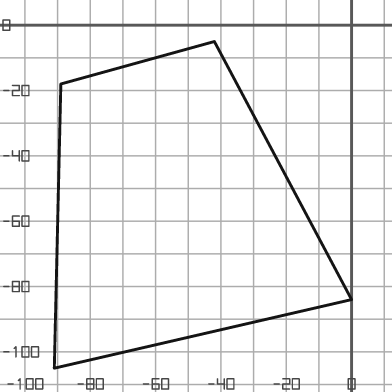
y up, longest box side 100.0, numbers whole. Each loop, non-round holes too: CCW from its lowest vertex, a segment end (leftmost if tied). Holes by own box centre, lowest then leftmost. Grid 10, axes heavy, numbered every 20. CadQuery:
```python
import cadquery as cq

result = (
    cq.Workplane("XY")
    .moveTo(-91.0, -105.0)
    .lineTo(0.0, -84.0)
    .lineTo(-42.0, -5.0)
    .lineTo(-89.0, -18.0)
    .close()
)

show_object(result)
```